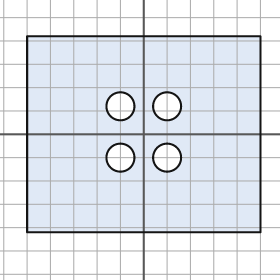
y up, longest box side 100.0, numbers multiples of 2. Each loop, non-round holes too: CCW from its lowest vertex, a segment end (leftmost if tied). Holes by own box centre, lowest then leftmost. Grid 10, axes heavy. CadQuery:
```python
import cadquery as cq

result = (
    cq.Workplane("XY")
    .moveTo(-50.0, -42.0)
    .lineTo(50.0, -42.0)
    .lineTo(50.0, 42.0)
    .lineTo(-50.0, 42.0)
    .close()
    .moveTo(-10.0, -10.0)
    .circle(6.0)
    .moveTo(10.0, -10.0)
    .circle(6.0)
    .moveTo(-10.0, 12.0)
    .circle(6.0)
    .moveTo(10.0, 12.0)
    .circle(6.0)
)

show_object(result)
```